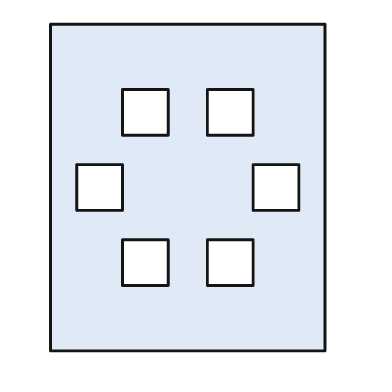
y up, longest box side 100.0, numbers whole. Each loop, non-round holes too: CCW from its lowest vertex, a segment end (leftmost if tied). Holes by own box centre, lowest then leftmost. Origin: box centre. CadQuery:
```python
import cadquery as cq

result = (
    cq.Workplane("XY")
    .moveTo(-42.0, -50.0)
    .lineTo(42.0, -50.0)
    .lineTo(42.0, 50.0)
    .lineTo(-42.0, 50.0)
    .close()
    .moveTo(-20.0, -30.0)
    .lineTo(-6.0, -30.0)
    .lineTo(-6.0, -16.0)
    .lineTo(-20.0, -16.0)
    .close()
    .moveTo(6.0, -30.0)
    .lineTo(20.0, -30.0)
    .lineTo(20.0, -16.0)
    .lineTo(6.0, -16.0)
    .close()
    .moveTo(-34.0, -7.0)
    .lineTo(-20.0, -7.0)
    .lineTo(-20.0, 7.0)
    .lineTo(-34.0, 7.0)
    .close()
    .moveTo(20.0, -7.0)
    .lineTo(34.0, -7.0)
    .lineTo(34.0, 7.0)
    .lineTo(20.0, 7.0)
    .close()
    .moveTo(-20.0, 16.0)
    .lineTo(-6.0, 16.0)
    .lineTo(-6.0, 30.0)
    .lineTo(-20.0, 30.0)
    .close()
    .moveTo(6.0, 16.0)
    .lineTo(20.0, 16.0)
    .lineTo(20.0, 30.0)
    .lineTo(6.0, 30.0)
    .close()
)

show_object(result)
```